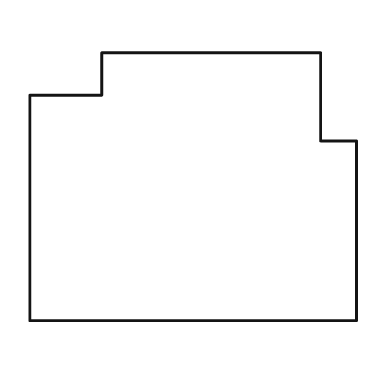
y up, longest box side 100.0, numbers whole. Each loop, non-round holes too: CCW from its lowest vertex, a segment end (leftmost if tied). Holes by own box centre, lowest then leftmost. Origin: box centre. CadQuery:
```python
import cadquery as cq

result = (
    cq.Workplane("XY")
    .moveTo(-50.0, -41.0)
    .lineTo(50.0, -41.0)
    .lineTo(50.0, 14.0)
    .lineTo(39.0, 14.0)
    .lineTo(39.0, 41.0)
    .lineTo(-28.0, 41.0)
    .lineTo(-28.0, 28.0)
    .lineTo(-50.0, 28.0)
    .close()
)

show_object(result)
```